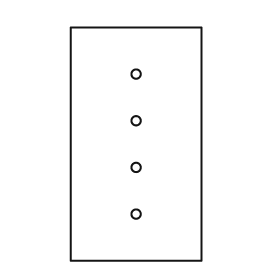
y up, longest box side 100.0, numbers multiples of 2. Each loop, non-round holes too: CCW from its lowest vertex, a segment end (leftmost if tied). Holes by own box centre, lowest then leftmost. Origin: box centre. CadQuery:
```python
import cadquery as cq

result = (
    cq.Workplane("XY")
    .moveTo(-28.0, -50.0)
    .lineTo(28.0, -50.0)
    .lineTo(28.0, 50.0)
    .lineTo(-28.0, 50.0)
    .close()
    .moveTo(0.0, -30.0)
    .circle(2.0)
    .moveTo(0.0, -10.0)
    .circle(2.0)
    .moveTo(0.0, 10.0)
    .circle(2.0)
    .moveTo(0.0, 30.0)
    .circle(2.0)
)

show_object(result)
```